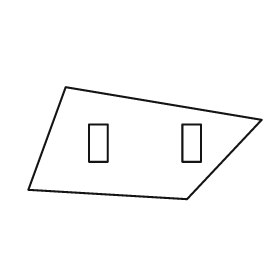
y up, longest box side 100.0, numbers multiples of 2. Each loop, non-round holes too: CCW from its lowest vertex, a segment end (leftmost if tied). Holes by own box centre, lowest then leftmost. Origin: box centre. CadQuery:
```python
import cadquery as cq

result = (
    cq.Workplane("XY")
    .moveTo(18.0, -24.0)
    .lineTo(50.0, 10.0)
    .lineTo(-34.0, 24.0)
    .lineTo(-50.0, -20.0)
    .close()
    .moveTo(-24.0, -8.0)
    .lineTo(-16.0, -8.0)
    .lineTo(-16.0, 8.0)
    .lineTo(-24.0, 8.0)
    .close()
    .moveTo(16.0, -8.0)
    .lineTo(24.0, -8.0)
    .lineTo(24.0, 8.0)
    .lineTo(16.0, 8.0)
    .close()
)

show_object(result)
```